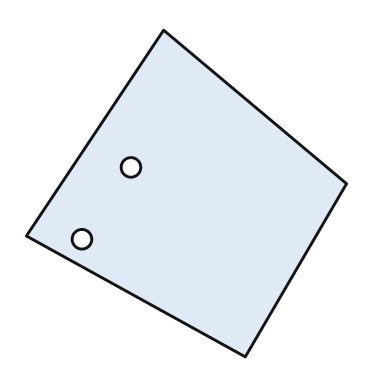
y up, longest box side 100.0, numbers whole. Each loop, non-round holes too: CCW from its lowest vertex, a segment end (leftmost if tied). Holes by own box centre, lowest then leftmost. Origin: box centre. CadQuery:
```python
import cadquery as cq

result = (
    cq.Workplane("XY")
    .moveTo(18.0, -50.0)
    .lineTo(49.0, 3.0)
    .lineTo(-7.0, 50.0)
    .lineTo(-49.0, -13.0)
    .close()
    .moveTo(-32.0, -14.0)
    .circle(3.0)
    .moveTo(-17.0, 8.0)
    .circle(3.0)
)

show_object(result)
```